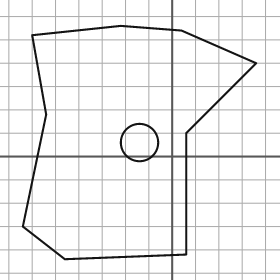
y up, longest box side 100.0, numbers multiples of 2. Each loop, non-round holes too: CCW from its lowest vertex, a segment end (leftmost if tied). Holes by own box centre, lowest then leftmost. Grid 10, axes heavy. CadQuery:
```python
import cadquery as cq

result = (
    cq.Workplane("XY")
    .moveTo(-46.0, -44.0)
    .lineTo(6.0, -42.0)
    .lineTo(6.0, 10.0)
    .lineTo(36.0, 40.0)
    .lineTo(4.0, 54.0)
    .lineTo(-22.0, 56.0)
    .lineTo(-60.0, 52.0)
    .lineTo(-54.0, 18.0)
    .lineTo(-64.0, -30.0)
    .close()
    .moveTo(-14.0, 6.0)
    .circle(8.0)
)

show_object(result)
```